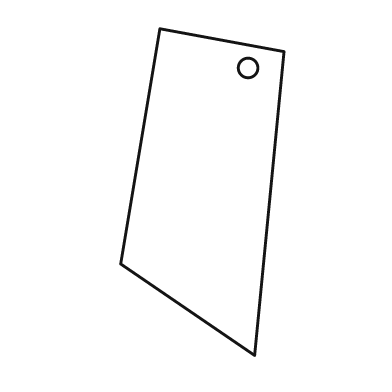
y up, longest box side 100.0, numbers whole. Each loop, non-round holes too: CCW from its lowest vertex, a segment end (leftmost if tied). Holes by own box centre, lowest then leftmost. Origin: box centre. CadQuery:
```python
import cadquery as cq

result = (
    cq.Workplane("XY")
    .moveTo(16.0, -50.0)
    .lineTo(25.0, 43.0)
    .lineTo(-13.0, 50.0)
    .lineTo(-25.0, -22.0)
    .close()
    .moveTo(14.0, 38.0)
    .circle(3.0)
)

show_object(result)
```